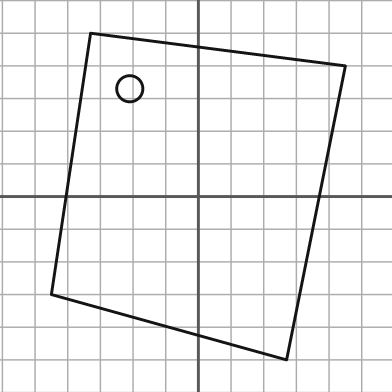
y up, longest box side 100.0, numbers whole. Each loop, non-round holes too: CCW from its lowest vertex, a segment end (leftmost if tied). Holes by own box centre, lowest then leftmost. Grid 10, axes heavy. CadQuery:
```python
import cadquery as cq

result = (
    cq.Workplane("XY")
    .moveTo(27.0, -50.0)
    .lineTo(45.0, 40.0)
    .lineTo(-33.0, 50.0)
    .lineTo(-45.0, -30.0)
    .close()
    .moveTo(-21.0, 33.0)
    .circle(4.0)
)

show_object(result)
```